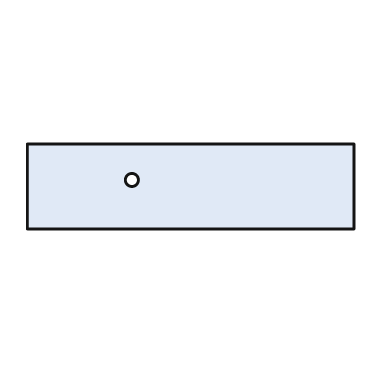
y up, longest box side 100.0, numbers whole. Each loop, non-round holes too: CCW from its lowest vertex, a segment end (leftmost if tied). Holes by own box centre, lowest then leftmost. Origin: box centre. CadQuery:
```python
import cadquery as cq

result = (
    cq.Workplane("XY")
    .moveTo(-50.0, -13.0)
    .lineTo(50.0, -13.0)
    .lineTo(50.0, 13.0)
    .lineTo(-50.0, 13.0)
    .close()
    .moveTo(-18.0, 2.0)
    .circle(2.0)
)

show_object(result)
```